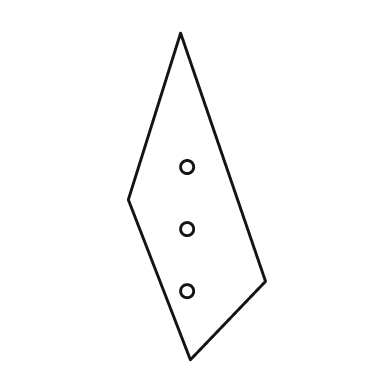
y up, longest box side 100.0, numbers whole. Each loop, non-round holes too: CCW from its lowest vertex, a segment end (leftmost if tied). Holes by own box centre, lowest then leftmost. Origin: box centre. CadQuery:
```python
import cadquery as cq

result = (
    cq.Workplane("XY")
    .moveTo(-2.0, -50.0)
    .lineTo(21.0, -26.0)
    .lineTo(-5.0, 50.0)
    .lineTo(-21.0, -1.0)
    .close()
    .moveTo(-3.0, -29.0)
    .circle(2.0)
    .moveTo(-3.0, -10.0)
    .circle(2.0)
    .moveTo(-3.0, 9.0)
    .circle(2.0)
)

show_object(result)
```